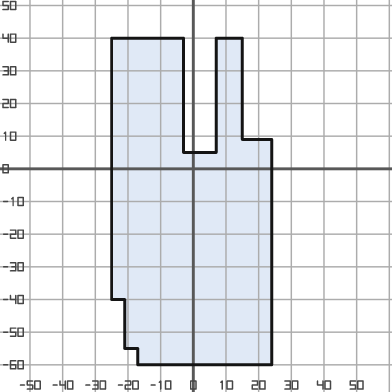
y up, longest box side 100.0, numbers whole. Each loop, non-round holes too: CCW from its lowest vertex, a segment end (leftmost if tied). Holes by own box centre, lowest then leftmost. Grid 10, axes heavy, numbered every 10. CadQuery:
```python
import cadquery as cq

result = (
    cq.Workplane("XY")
    .moveTo(-17.0, -60.0)
    .lineTo(24.0, -60.0)
    .lineTo(24.0, 9.0)
    .lineTo(15.0, 9.0)
    .lineTo(15.0, 40.0)
    .lineTo(7.0, 40.0)
    .lineTo(7.0, 5.0)
    .lineTo(-3.0, 5.0)
    .lineTo(-3.0, 40.0)
    .lineTo(-25.0, 40.0)
    .lineTo(-25.0, -40.0)
    .lineTo(-21.0, -40.0)
    .lineTo(-21.0, -55.0)
    .lineTo(-17.0, -55.0)
    .close()
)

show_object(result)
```